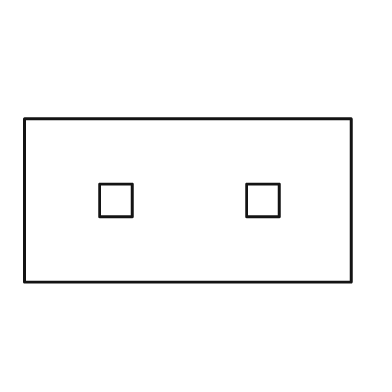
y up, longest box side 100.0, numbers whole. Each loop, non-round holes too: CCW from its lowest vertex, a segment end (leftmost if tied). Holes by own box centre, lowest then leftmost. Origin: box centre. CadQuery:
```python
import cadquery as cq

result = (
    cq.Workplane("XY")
    .moveTo(-50.0, -25.0)
    .lineTo(50.0, -25.0)
    .lineTo(50.0, 25.0)
    .lineTo(-50.0, 25.0)
    .close()
    .moveTo(-27.0, -5.0)
    .lineTo(-17.0, -5.0)
    .lineTo(-17.0, 5.0)
    .lineTo(-27.0, 5.0)
    .close()
    .moveTo(18.0, -5.0)
    .lineTo(28.0, -5.0)
    .lineTo(28.0, 5.0)
    .lineTo(18.0, 5.0)
    .close()
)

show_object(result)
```